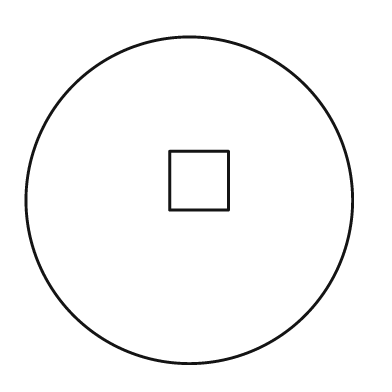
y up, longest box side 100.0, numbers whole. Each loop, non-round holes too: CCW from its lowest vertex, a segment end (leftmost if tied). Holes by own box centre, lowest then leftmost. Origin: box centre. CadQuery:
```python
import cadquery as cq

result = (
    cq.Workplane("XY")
    .moveTo(0.0, 0.0)
    .circle(50.0)
    .moveTo(-6.0, -3.0)
    .lineTo(12.0, -3.0)
    .lineTo(12.0, 15.0)
    .lineTo(-6.0, 15.0)
    .close()
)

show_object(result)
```